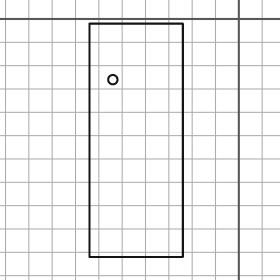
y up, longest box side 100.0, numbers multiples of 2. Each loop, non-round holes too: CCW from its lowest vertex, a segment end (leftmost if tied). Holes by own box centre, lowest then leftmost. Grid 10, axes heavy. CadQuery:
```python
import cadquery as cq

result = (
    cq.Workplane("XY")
    .moveTo(-64.0, -102.0)
    .lineTo(-24.0, -102.0)
    .lineTo(-24.0, -2.0)
    .lineTo(-64.0, -2.0)
    .close()
    .moveTo(-54.0, -26.0)
    .circle(2.0)
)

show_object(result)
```